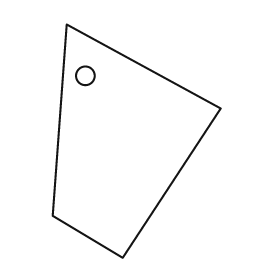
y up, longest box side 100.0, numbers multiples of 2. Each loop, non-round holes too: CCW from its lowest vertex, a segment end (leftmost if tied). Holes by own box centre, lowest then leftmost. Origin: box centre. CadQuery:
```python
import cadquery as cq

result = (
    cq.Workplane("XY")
    .moveTo(-6.0, -50.0)
    .lineTo(36.0, 14.0)
    .lineTo(-30.0, 50.0)
    .lineTo(-36.0, -32.0)
    .close()
    .moveTo(-22.0, 28.0)
    .circle(4.0)
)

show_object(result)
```